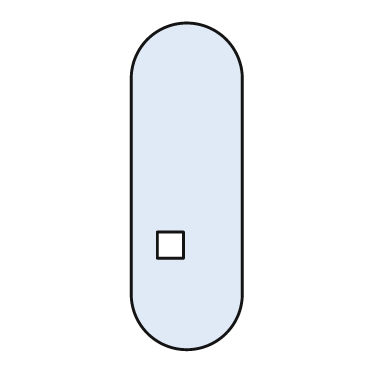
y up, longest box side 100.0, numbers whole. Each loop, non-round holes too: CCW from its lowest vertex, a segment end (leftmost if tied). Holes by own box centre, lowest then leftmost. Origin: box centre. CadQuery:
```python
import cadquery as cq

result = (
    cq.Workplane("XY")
    .moveTo(-17.0, -33.0)
    .threePointArc((0.0, -50.0), (17.0, -33.0))
    .lineTo(17.0, 33.0)
    .threePointArc((0.0, 50.0), (-17.0, 33.0))
    .close()
    .moveTo(-9.0, -22.0)
    .lineTo(-1.0, -22.0)
    .lineTo(-1.0, -14.0)
    .lineTo(-9.0, -14.0)
    .close()
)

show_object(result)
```